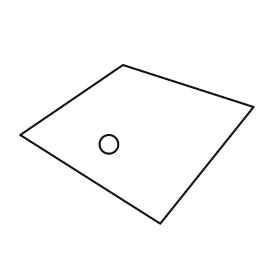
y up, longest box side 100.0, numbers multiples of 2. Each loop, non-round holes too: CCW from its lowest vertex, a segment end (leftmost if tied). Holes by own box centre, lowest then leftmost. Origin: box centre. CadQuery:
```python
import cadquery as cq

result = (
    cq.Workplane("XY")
    .moveTo(10.0, -34.0)
    .lineTo(50.0, 16.0)
    .lineTo(-6.0, 34.0)
    .lineTo(-50.0, 4.0)
    .close()
    .moveTo(-12.0, 0.0)
    .circle(4.0)
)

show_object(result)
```